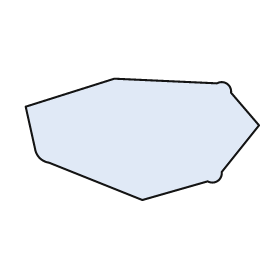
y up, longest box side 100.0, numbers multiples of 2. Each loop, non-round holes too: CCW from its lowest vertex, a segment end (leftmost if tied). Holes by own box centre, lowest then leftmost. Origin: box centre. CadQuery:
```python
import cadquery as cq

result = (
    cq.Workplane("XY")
    .moveTo(0.0, -26.0)
    .lineTo(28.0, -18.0)
    .threePointArc((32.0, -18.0), (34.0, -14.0))
    .lineTo(50.0, 6.0)
    .lineTo(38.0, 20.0)
    .threePointArc((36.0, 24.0), (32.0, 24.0))
    .lineTo(-12.0, 26.0)
    .lineTo(-50.0, 14.0)
    .lineTo(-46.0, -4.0)
    .threePointArc((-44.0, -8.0), (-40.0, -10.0))
    .close()
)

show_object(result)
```